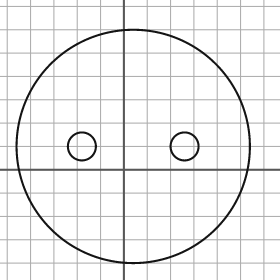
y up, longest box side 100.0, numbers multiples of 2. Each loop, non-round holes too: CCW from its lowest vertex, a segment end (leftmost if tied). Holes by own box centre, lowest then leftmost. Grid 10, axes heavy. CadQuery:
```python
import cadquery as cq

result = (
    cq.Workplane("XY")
    .moveTo(4.0, 10.0)
    .circle(50.0)
    .moveTo(-18.0, 10.0)
    .circle(6.0)
    .moveTo(26.0, 10.0)
    .circle(6.0)
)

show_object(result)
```